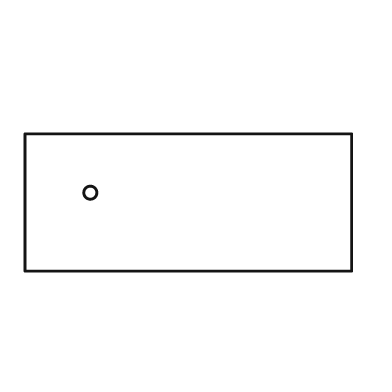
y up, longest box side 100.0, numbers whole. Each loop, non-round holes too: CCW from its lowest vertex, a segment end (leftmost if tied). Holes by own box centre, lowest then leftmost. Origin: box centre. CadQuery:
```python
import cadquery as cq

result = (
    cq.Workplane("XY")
    .moveTo(-50.0, -21.0)
    .lineTo(50.0, -21.0)
    .lineTo(50.0, 21.0)
    .lineTo(-50.0, 21.0)
    .close()
    .moveTo(-30.0, 3.0)
    .circle(2.0)
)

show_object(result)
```